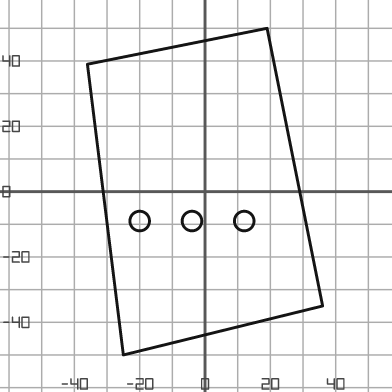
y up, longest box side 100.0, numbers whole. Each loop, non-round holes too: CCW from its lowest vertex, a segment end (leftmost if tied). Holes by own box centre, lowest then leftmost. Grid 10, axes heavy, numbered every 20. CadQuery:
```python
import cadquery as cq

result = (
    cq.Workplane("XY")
    .moveTo(-25.0, -50.0)
    .lineTo(36.0, -35.0)
    .lineTo(19.0, 50.0)
    .lineTo(-36.0, 39.0)
    .close()
    .moveTo(-20.0, -9.0)
    .circle(3.0)
    .moveTo(-4.0, -9.0)
    .circle(3.0)
    .moveTo(12.0, -9.0)
    .circle(3.0)
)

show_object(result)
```